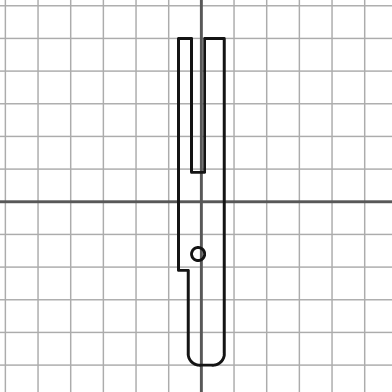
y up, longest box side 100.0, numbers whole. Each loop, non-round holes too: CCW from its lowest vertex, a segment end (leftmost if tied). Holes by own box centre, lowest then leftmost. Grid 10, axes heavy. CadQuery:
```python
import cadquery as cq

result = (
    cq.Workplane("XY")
    .moveTo(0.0, -50.0)
    .lineTo(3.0, -50.0)
    .threePointArc((6.0, -49.0), (7.0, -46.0))
    .lineTo(7.0, 50.0)
    .lineTo(1.0, 50.0)
    .lineTo(1.0, 9.0)
    .lineTo(-3.0, 9.0)
    .lineTo(-3.0, 50.0)
    .lineTo(-7.0, 50.0)
    .lineTo(-7.0, -21.0)
    .lineTo(-4.0, -21.0)
    .lineTo(-4.0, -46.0)
    .threePointArc((-3.0, -49.0), (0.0, -50.0))
    .close()
    .moveTo(-1.0, -16.0)
    .circle(2.0)
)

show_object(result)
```